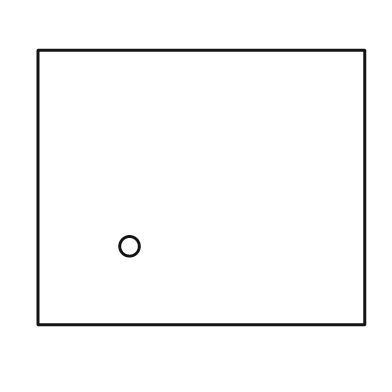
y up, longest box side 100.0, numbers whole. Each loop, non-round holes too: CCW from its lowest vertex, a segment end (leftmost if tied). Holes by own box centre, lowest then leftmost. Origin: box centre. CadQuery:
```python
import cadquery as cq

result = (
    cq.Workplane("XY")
    .moveTo(-50.0, -42.0)
    .lineTo(50.0, -42.0)
    .lineTo(50.0, 42.0)
    .lineTo(-50.0, 42.0)
    .close()
    .moveTo(-22.0, -18.0)
    .circle(3.0)
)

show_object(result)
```